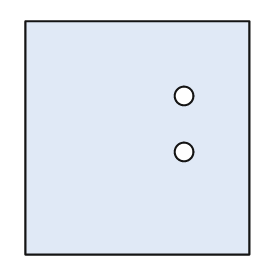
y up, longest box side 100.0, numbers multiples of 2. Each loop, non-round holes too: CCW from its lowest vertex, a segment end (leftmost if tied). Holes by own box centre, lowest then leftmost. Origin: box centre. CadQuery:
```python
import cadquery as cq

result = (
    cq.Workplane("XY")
    .moveTo(-48.0, -50.0)
    .lineTo(48.0, -50.0)
    .lineTo(48.0, 50.0)
    .lineTo(-48.0, 50.0)
    .close()
    .moveTo(20.0, -6.0)
    .circle(4.0)
    .moveTo(20.0, 18.0)
    .circle(4.0)
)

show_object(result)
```